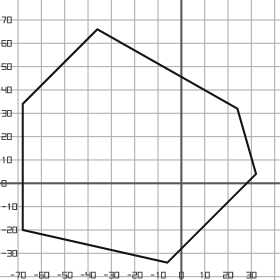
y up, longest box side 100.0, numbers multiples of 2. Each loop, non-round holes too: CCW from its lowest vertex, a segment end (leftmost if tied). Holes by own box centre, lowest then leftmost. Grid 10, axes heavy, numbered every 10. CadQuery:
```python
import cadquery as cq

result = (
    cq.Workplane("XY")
    .moveTo(-6.0, -34.0)
    .lineTo(32.0, 4.0)
    .lineTo(24.0, 32.0)
    .lineTo(-36.0, 66.0)
    .lineTo(-68.0, 34.0)
    .lineTo(-68.0, -20.0)
    .close()
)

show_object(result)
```